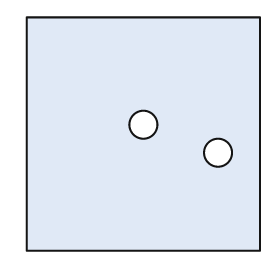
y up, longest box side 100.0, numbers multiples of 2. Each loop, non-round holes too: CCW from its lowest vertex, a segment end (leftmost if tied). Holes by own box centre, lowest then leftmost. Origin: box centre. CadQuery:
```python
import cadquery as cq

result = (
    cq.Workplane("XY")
    .moveTo(-50.0, -50.0)
    .lineTo(50.0, -50.0)
    .lineTo(50.0, 50.0)
    .lineTo(-50.0, 50.0)
    .close()
    .moveTo(32.0, -8.0)
    .circle(6.0)
    .moveTo(0.0, 4.0)
    .circle(6.0)
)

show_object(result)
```